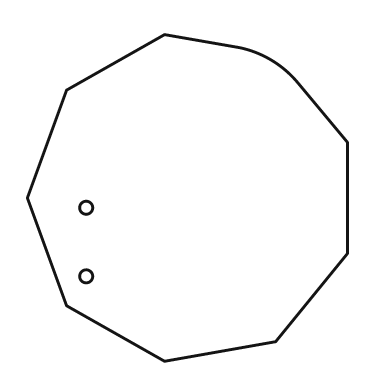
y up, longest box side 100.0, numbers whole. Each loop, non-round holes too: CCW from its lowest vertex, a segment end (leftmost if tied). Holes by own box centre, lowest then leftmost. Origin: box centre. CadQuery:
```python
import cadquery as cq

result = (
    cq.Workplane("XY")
    .moveTo(-7.0, -50.0)
    .lineTo(27.0, -44.0)
    .lineTo(49.0, -17.0)
    .lineTo(49.0, 17.0)
    .lineTo(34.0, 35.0)
    .threePointArc((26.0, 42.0), (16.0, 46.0))
    .lineTo(-7.0, 50.0)
    .lineTo(-37.0, 33.0)
    .lineTo(-49.0, 0.0)
    .lineTo(-37.0, -33.0)
    .close()
    .moveTo(-31.0, -24.0)
    .circle(2.0)
    .moveTo(-31.0, -3.0)
    .circle(2.0)
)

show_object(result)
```